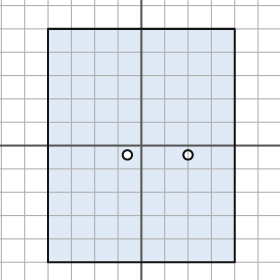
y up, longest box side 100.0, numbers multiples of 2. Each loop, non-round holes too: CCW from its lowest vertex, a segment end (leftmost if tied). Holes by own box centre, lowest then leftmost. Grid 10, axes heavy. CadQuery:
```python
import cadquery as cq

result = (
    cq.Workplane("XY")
    .moveTo(-40.0, -50.0)
    .lineTo(40.0, -50.0)
    .lineTo(40.0, 50.0)
    .lineTo(-40.0, 50.0)
    .close()
    .moveTo(-6.0, -4.0)
    .circle(2.0)
    .moveTo(20.0, -4.0)
    .circle(2.0)
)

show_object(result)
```